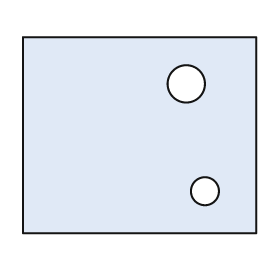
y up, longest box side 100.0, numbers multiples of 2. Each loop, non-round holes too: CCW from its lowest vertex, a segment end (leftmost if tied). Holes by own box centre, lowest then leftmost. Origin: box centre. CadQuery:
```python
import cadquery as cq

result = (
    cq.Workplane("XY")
    .moveTo(-50.0, -42.0)
    .lineTo(50.0, -42.0)
    .lineTo(50.0, 42.0)
    .lineTo(-50.0, 42.0)
    .close()
    .moveTo(28.0, -24.0)
    .circle(6.0)
    .moveTo(20.0, 22.0)
    .circle(8.0)
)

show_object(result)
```